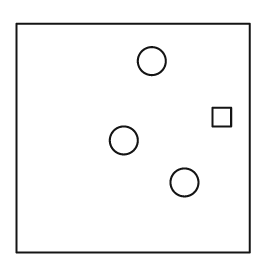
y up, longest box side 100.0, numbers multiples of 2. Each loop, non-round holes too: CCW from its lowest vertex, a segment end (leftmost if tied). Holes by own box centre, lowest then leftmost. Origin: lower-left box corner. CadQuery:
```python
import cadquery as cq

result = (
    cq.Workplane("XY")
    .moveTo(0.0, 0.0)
    .lineTo(100.0, 0.0)
    .lineTo(100.0, 98.0)
    .lineTo(0.0, 98.0)
    .close()
    .moveTo(72.0, 30.0)
    .circle(6.0)
    .moveTo(46.0, 48.0)
    .circle(6.0)
    .moveTo(84.0, 54.0)
    .lineTo(92.0, 54.0)
    .lineTo(92.0, 62.0)
    .lineTo(84.0, 62.0)
    .close()
    .moveTo(58.0, 82.0)
    .circle(6.0)
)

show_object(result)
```